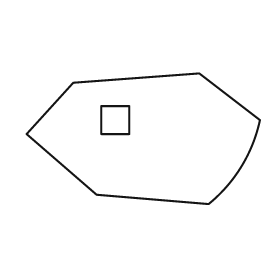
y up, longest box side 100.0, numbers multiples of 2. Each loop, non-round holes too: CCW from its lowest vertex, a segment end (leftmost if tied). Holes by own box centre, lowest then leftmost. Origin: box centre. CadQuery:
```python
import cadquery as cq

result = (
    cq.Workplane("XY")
    .moveTo(28.0, -28.0)
    .threePointArc((42.0, -12.0), (50.0, 8.0))
    .lineTo(24.0, 28.0)
    .lineTo(-30.0, 24.0)
    .lineTo(-50.0, 2.0)
    .lineTo(-20.0, -24.0)
    .close()
    .moveTo(-18.0, 2.0)
    .lineTo(-6.0, 2.0)
    .lineTo(-6.0, 14.0)
    .lineTo(-18.0, 14.0)
    .close()
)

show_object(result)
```